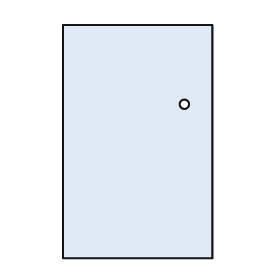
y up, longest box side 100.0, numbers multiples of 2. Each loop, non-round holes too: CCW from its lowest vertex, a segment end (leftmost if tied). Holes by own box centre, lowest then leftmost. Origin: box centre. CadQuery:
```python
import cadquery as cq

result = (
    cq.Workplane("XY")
    .moveTo(-32.0, -50.0)
    .lineTo(32.0, -50.0)
    .lineTo(32.0, 50.0)
    .lineTo(-32.0, 50.0)
    .close()
    .moveTo(20.0, 16.0)
    .circle(2.0)
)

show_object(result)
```